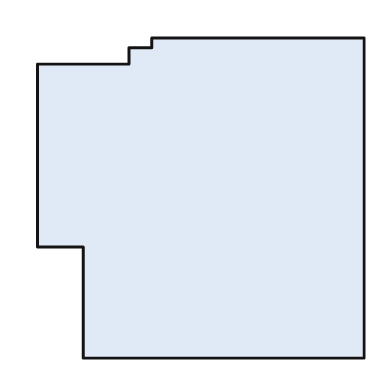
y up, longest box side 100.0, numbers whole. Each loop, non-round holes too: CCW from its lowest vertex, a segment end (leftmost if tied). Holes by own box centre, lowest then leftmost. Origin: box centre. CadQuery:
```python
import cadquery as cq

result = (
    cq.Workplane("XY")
    .moveTo(-36.0, -49.0)
    .lineTo(50.0, -49.0)
    .lineTo(50.0, 49.0)
    .lineTo(-15.0, 49.0)
    .lineTo(-15.0, 46.0)
    .lineTo(-22.0, 46.0)
    .lineTo(-22.0, 41.0)
    .lineTo(-50.0, 41.0)
    .lineTo(-50.0, -15.0)
    .lineTo(-36.0, -15.0)
    .close()
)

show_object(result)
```